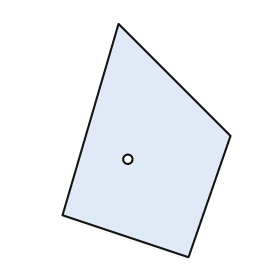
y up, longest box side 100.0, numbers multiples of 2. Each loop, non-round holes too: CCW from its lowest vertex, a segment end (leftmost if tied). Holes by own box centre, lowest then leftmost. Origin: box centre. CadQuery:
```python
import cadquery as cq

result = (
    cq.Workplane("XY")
    .moveTo(18.0, -50.0)
    .lineTo(36.0, 2.0)
    .lineTo(-12.0, 50.0)
    .lineTo(-36.0, -32.0)
    .close()
    .moveTo(-8.0, -8.0)
    .circle(2.0)
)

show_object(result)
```